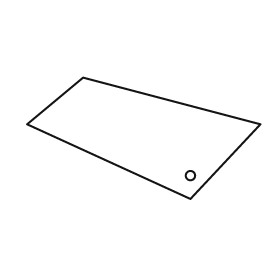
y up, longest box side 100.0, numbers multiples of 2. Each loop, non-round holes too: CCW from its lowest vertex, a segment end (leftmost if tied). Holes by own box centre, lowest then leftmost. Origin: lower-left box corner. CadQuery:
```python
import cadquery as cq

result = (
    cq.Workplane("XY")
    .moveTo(70.0, 0.0)
    .lineTo(100.0, 32.0)
    .lineTo(24.0, 52.0)
    .lineTo(0.0, 32.0)
    .close()
    .moveTo(70.0, 10.0)
    .circle(2.0)
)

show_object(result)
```